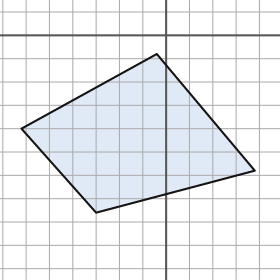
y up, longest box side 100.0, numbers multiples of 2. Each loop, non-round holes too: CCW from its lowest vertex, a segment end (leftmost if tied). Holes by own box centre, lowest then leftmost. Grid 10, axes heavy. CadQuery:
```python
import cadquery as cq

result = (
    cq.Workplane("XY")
    .moveTo(-30.0, -76.0)
    .lineTo(38.0, -58.0)
    .lineTo(-4.0, -8.0)
    .lineTo(-62.0, -40.0)
    .close()
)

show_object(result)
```